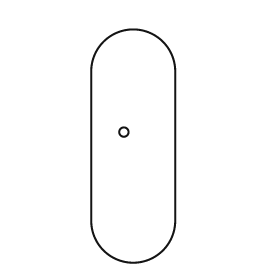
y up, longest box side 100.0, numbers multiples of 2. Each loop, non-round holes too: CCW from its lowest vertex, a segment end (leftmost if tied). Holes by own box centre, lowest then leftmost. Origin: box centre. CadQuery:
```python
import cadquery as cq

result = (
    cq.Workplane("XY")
    .moveTo(-18.0, -32.0)
    .threePointArc((0.0, -50.0), (18.0, -32.0))
    .lineTo(18.0, 32.0)
    .threePointArc((0.0, 50.0), (-18.0, 32.0))
    .close()
    .moveTo(-4.0, 6.0)
    .circle(2.0)
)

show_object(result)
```